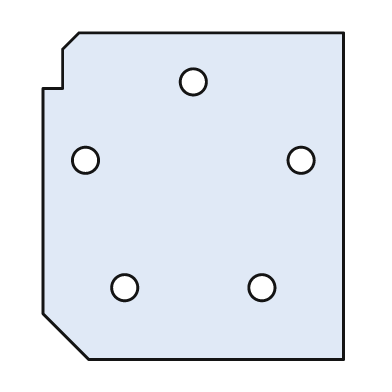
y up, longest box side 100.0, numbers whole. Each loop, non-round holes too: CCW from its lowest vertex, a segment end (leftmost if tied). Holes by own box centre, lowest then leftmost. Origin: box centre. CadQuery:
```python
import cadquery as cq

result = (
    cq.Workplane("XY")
    .moveTo(-32.0, -50.0)
    .lineTo(46.0, -50.0)
    .lineTo(46.0, 50.0)
    .lineTo(-35.0, 50.0)
    .lineTo(-40.0, 45.0)
    .lineTo(-40.0, 33.0)
    .lineTo(-46.0, 33.0)
    .lineTo(-46.0, -36.0)
    .close()
    .moveTo(-21.0, -28.0)
    .circle(4.0)
    .moveTo(21.0, -28.0)
    .circle(4.0)
    .moveTo(-33.0, 11.0)
    .circle(4.0)
    .moveTo(33.0, 11.0)
    .circle(4.0)
    .moveTo(0.0, 35.0)
    .circle(4.0)
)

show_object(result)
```